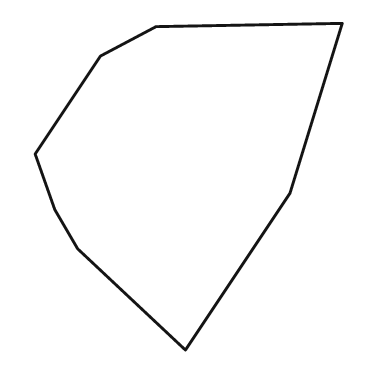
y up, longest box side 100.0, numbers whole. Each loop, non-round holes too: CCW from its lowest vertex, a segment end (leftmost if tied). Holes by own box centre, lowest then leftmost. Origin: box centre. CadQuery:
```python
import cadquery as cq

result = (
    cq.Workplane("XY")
    .moveTo(-1.0, -50.0)
    .lineTo(31.0, -2.0)
    .lineTo(47.0, 50.0)
    .lineTo(-10.0, 49.0)
    .lineTo(-27.0, 40.0)
    .lineTo(-47.0, 10.0)
    .lineTo(-41.0, -7.0)
    .lineTo(-34.0, -19.0)
    .close()
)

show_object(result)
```